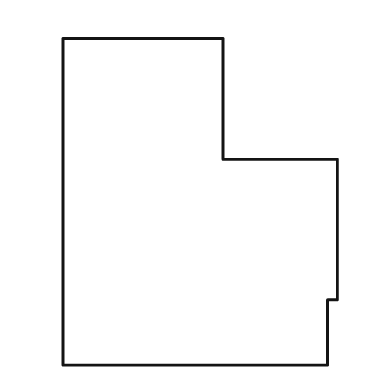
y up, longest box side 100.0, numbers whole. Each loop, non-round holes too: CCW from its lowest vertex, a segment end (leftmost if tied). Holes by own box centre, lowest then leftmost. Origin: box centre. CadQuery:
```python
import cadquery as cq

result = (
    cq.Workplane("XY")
    .moveTo(-42.0, -50.0)
    .lineTo(39.0, -50.0)
    .lineTo(39.0, -30.0)
    .lineTo(42.0, -30.0)
    .lineTo(42.0, 13.0)
    .lineTo(7.0, 13.0)
    .lineTo(7.0, 50.0)
    .lineTo(-42.0, 50.0)
    .close()
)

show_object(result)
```